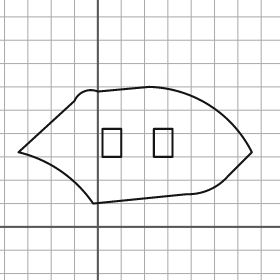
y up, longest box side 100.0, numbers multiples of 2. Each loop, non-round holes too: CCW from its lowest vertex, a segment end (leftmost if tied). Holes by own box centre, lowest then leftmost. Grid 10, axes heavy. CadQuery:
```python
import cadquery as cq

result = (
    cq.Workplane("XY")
    .moveTo(-2.0, 10.0)
    .lineTo(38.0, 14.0)
    .threePointArc((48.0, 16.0), (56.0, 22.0))
    .lineTo(66.0, 32.0)
    .threePointArc((48.0, 52.0), (22.0, 60.0))
    .lineTo(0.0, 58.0)
    .threePointArc((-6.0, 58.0), (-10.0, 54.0))
    .lineTo(-34.0, 32.0)
    .threePointArc((-16.0, 24.0), (-2.0, 10.0))
    .close()
    .moveTo(2.0, 30.0)
    .lineTo(10.0, 30.0)
    .lineTo(10.0, 42.0)
    .lineTo(2.0, 42.0)
    .close()
    .moveTo(24.0, 30.0)
    .lineTo(32.0, 30.0)
    .lineTo(32.0, 42.0)
    .lineTo(24.0, 42.0)
    .close()
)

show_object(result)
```